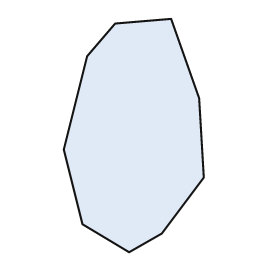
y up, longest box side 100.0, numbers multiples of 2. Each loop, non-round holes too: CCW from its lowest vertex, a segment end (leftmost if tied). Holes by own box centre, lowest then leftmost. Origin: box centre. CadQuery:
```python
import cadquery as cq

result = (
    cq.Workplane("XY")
    .moveTo(-2.0, -50.0)
    .lineTo(12.0, -42.0)
    .lineTo(30.0, -18.0)
    .lineTo(28.0, 16.0)
    .lineTo(16.0, 50.0)
    .lineTo(-8.0, 48.0)
    .lineTo(-20.0, 34.0)
    .lineTo(-30.0, -6.0)
    .lineTo(-22.0, -38.0)
    .close()
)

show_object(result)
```